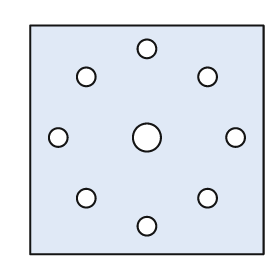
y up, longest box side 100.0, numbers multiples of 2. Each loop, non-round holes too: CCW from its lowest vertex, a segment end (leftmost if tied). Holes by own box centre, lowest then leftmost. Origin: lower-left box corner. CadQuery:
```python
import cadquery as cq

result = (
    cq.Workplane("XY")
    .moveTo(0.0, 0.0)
    .lineTo(100.0, 0.0)
    .lineTo(100.0, 98.0)
    .lineTo(0.0, 98.0)
    .close()
    .moveTo(50.0, 12.0)
    .circle(4.0)
    .moveTo(24.0, 24.0)
    .circle(4.0)
    .moveTo(76.0, 24.0)
    .circle(4.0)
    .moveTo(12.0, 50.0)
    .circle(4.0)
    .moveTo(50.0, 50.0)
    .circle(6.0)
    .moveTo(88.0, 50.0)
    .circle(4.0)
    .moveTo(24.0, 76.0)
    .circle(4.0)
    .moveTo(76.0, 76.0)
    .circle(4.0)
    .moveTo(50.0, 88.0)
    .circle(4.0)
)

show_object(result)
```